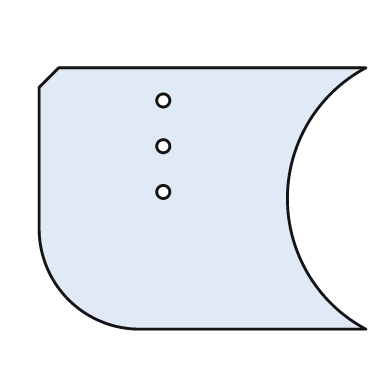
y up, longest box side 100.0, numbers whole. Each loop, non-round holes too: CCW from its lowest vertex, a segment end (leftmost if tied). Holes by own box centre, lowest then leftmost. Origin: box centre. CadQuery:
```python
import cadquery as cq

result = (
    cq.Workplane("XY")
    .moveTo(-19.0, -40.0)
    .lineTo(50.0, -40.0)
    .threePointArc((26.0, 0.0), (50.0, 40.0))
    .lineTo(-44.0, 40.0)
    .lineTo(-50.0, 34.0)
    .lineTo(-50.0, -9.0)
    .threePointArc((-41.0, -31.0), (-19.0, -40.0))
    .close()
    .moveTo(-12.0, 2.0)
    .circle(2.0)
    .moveTo(-12.0, 16.0)
    .circle(2.0)
    .moveTo(-12.0, 30.0)
    .circle(2.0)
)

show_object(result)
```